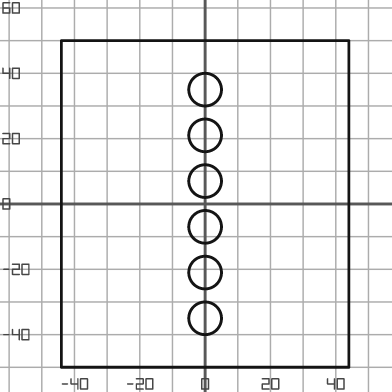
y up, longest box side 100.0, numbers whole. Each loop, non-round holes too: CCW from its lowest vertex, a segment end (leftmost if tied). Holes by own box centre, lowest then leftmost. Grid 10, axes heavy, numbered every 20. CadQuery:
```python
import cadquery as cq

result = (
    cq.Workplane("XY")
    .moveTo(-44.0, -50.0)
    .lineTo(44.0, -50.0)
    .lineTo(44.0, 50.0)
    .lineTo(-44.0, 50.0)
    .close()
    .moveTo(0.0, -35.0)
    .circle(5.0)
    .moveTo(0.0, -21.0)
    .circle(5.0)
    .moveTo(0.0, -7.0)
    .circle(5.0)
    .moveTo(0.0, 7.0)
    .circle(5.0)
    .moveTo(0.0, 21.0)
    .circle(5.0)
    .moveTo(0.0, 35.0)
    .circle(5.0)
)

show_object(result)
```